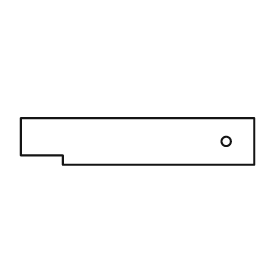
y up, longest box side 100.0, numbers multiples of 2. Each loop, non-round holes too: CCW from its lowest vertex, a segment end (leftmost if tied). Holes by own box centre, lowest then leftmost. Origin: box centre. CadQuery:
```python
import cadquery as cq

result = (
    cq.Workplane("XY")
    .moveTo(-32.0, -10.0)
    .lineTo(50.0, -10.0)
    .lineTo(50.0, 10.0)
    .lineTo(-50.0, 10.0)
    .lineTo(-50.0, -6.0)
    .lineTo(-32.0, -6.0)
    .close()
    .moveTo(38.0, 0.0)
    .circle(2.0)
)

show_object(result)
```